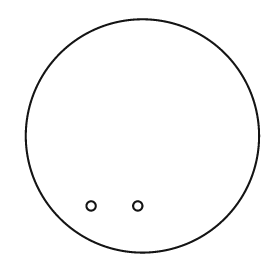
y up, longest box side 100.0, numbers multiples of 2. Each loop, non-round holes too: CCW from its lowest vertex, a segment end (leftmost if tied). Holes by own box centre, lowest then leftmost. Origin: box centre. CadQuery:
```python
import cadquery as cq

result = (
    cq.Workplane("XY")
    .moveTo(0.0, 0.0)
    .circle(50.0)
    .moveTo(-22.0, -30.0)
    .circle(2.0)
    .moveTo(-2.0, -30.0)
    .circle(2.0)
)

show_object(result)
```